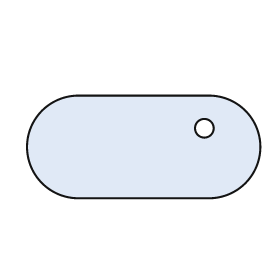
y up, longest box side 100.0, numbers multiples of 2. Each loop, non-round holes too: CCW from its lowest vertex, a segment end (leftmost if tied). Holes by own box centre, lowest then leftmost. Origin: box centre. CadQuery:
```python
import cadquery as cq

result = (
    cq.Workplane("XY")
    .moveTo(-28.0, -22.0)
    .lineTo(28.0, -22.0)
    .threePointArc((50.0, 0.0), (28.0, 22.0))
    .lineTo(-28.0, 22.0)
    .threePointArc((-50.0, 0.0), (-28.0, -22.0))
    .close()
    .moveTo(26.0, 8.0)
    .circle(4.0)
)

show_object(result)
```